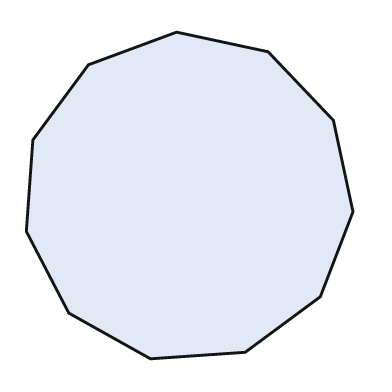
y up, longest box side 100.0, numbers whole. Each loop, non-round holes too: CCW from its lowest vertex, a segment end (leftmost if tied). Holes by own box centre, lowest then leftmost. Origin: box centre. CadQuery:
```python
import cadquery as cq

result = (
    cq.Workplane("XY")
    .moveTo(-12.0, -50.0)
    .lineTo(17.0, -48.0)
    .lineTo(40.0, -31.0)
    .lineTo(50.0, -5.0)
    .lineTo(44.0, 23.0)
    .lineTo(24.0, 44.0)
    .lineTo(-4.0, 50.0)
    .lineTo(-31.0, 40.0)
    .lineTo(-48.0, 17.0)
    .lineTo(-50.0, -11.0)
    .lineTo(-37.0, -36.0)
    .close()
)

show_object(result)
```